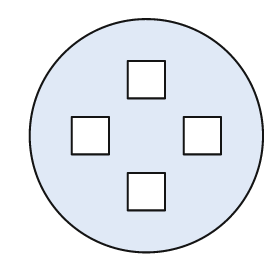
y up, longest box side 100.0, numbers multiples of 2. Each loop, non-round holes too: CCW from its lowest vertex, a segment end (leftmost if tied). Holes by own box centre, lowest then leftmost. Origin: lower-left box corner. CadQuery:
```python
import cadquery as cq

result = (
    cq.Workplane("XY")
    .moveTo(50.0, 50.0)
    .circle(50.0)
    .moveTo(42.0, 18.0)
    .lineTo(58.0, 18.0)
    .lineTo(58.0, 34.0)
    .lineTo(42.0, 34.0)
    .close()
    .moveTo(18.0, 42.0)
    .lineTo(34.0, 42.0)
    .lineTo(34.0, 58.0)
    .lineTo(18.0, 58.0)
    .close()
    .moveTo(66.0, 42.0)
    .lineTo(82.0, 42.0)
    .lineTo(82.0, 58.0)
    .lineTo(66.0, 58.0)
    .close()
    .moveTo(42.0, 66.0)
    .lineTo(58.0, 66.0)
    .lineTo(58.0, 82.0)
    .lineTo(42.0, 82.0)
    .close()
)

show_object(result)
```